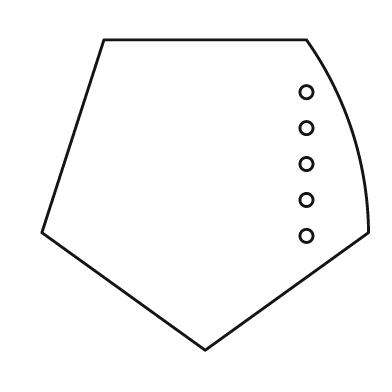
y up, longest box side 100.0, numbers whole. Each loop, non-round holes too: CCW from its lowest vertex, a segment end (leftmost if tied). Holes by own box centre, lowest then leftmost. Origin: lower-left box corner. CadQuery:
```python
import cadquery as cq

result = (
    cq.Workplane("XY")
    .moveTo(50.0, 0.0)
    .lineTo(100.0, 36.0)
    .threePointArc((95.0, 67.0), (81.0, 95.0))
    .lineTo(19.0, 95.0)
    .lineTo(0.0, 36.0)
    .close()
    .moveTo(81.0, 35.0)
    .circle(2.0)
    .moveTo(81.0, 46.0)
    .circle(2.0)
    .moveTo(81.0, 57.0)
    .circle(2.0)
    .moveTo(81.0, 68.0)
    .circle(2.0)
    .moveTo(81.0, 79.0)
    .circle(2.0)
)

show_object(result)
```